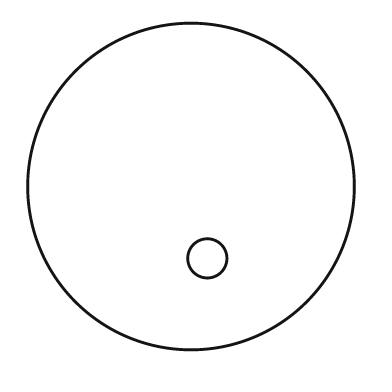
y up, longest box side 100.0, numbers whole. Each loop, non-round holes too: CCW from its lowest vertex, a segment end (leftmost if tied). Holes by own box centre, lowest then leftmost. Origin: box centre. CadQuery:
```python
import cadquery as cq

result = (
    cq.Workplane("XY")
    .moveTo(0.0, 0.0)
    .circle(50.0)
    .moveTo(5.0, -22.0)
    .circle(6.0)
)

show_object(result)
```